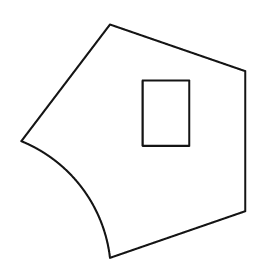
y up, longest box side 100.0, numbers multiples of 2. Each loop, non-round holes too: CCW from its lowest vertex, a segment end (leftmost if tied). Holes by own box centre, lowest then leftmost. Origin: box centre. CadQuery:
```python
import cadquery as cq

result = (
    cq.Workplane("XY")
    .moveTo(-10.0, -50.0)
    .lineTo(48.0, -30.0)
    .lineTo(48.0, 30.0)
    .lineTo(-10.0, 50.0)
    .lineTo(-48.0, 0.0)
    .threePointArc((-22.0, -20.0), (-10.0, -50.0))
    .close()
    .moveTo(4.0, -2.0)
    .lineTo(24.0, -2.0)
    .lineTo(24.0, 26.0)
    .lineTo(4.0, 26.0)
    .close()
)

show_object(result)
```